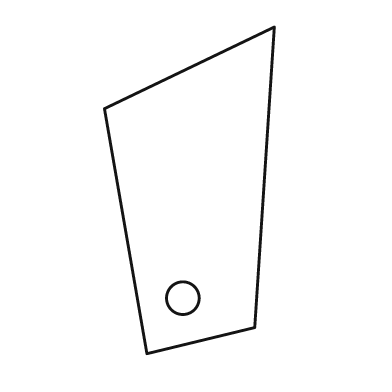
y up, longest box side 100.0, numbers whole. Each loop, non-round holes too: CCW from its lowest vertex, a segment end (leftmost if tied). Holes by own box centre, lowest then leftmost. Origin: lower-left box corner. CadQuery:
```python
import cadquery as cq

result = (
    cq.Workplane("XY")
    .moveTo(13.0, 0.0)
    .lineTo(46.0, 8.0)
    .lineTo(52.0, 100.0)
    .lineTo(0.0, 75.0)
    .close()
    .moveTo(24.0, 17.0)
    .circle(5.0)
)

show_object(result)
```